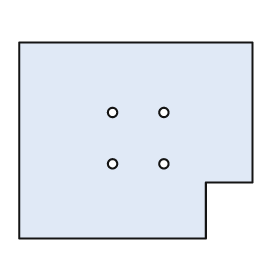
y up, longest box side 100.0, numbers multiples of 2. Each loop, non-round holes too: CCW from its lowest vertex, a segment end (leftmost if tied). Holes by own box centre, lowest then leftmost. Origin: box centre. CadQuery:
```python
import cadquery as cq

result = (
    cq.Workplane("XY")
    .moveTo(-50.0, -42.0)
    .lineTo(30.0, -42.0)
    .lineTo(30.0, -18.0)
    .lineTo(50.0, -18.0)
    .lineTo(50.0, 42.0)
    .lineTo(-50.0, 42.0)
    .close()
    .moveTo(-10.0, -10.0)
    .circle(2.0)
    .moveTo(12.0, -10.0)
    .circle(2.0)
    .moveTo(-10.0, 12.0)
    .circle(2.0)
    .moveTo(12.0, 12.0)
    .circle(2.0)
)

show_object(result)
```